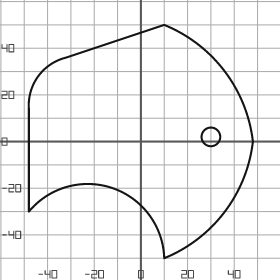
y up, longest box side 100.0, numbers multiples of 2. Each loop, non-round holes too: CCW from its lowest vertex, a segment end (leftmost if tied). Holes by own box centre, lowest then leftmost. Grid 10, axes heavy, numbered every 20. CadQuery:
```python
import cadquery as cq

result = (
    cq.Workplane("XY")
    .moveTo(10.0, -50.0)
    .threePointArc((36.0, -30.0), (48.0, 0.0))
    .threePointArc((36.0, 30.0), (10.0, 50.0))
    .lineTo(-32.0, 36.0)
    .threePointArc((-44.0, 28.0), (-48.0, 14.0))
    .lineTo(-48.0, -30.0)
    .threePointArc((-12.0, -20.0), (10.0, -50.0))
    .close()
    .moveTo(30.0, 2.0)
    .circle(4.0)
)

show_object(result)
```